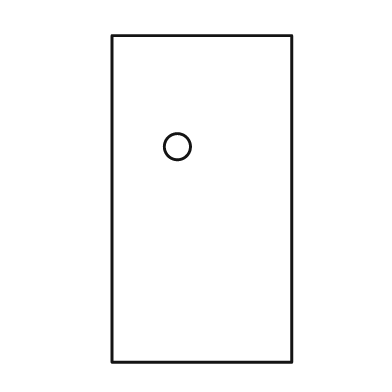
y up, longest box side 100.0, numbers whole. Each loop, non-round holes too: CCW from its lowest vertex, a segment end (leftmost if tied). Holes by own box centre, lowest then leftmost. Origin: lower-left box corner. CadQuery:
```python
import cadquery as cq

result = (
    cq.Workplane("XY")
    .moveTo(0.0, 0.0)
    .lineTo(55.0, 0.0)
    .lineTo(55.0, 100.0)
    .lineTo(0.0, 100.0)
    .close()
    .moveTo(20.0, 66.0)
    .circle(4.0)
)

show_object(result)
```